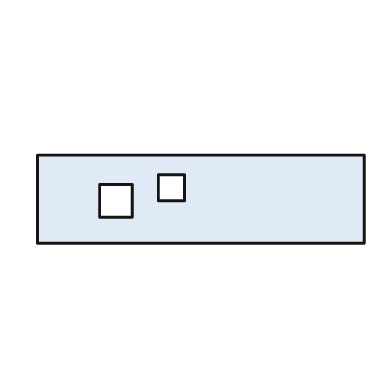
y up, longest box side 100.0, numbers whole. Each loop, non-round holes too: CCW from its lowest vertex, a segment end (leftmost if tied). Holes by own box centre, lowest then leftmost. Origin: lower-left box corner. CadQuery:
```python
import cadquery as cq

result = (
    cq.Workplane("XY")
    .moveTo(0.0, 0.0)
    .lineTo(100.0, 0.0)
    .lineTo(100.0, 27.0)
    .lineTo(0.0, 27.0)
    .close()
    .moveTo(19.0, 8.0)
    .lineTo(29.0, 8.0)
    .lineTo(29.0, 18.0)
    .lineTo(19.0, 18.0)
    .close()
    .moveTo(37.0, 13.0)
    .lineTo(45.0, 13.0)
    .lineTo(45.0, 21.0)
    .lineTo(37.0, 21.0)
    .close()
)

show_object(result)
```